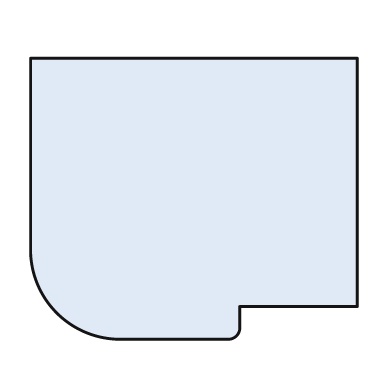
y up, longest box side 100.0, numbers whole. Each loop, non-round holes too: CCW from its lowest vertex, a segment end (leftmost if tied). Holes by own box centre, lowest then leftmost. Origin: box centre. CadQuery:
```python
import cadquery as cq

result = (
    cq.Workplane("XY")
    .moveTo(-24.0, -43.0)
    .lineTo(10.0, -43.0)
    .threePointArc((13.0, -42.0), (14.0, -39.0))
    .lineTo(14.0, -33.0)
    .lineTo(50.0, -33.0)
    .lineTo(50.0, 43.0)
    .lineTo(-50.0, 43.0)
    .lineTo(-50.0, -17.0)
    .threePointArc((-42.0, -35.0), (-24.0, -43.0))
    .close()
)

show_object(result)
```